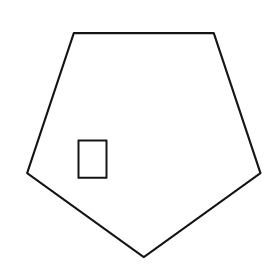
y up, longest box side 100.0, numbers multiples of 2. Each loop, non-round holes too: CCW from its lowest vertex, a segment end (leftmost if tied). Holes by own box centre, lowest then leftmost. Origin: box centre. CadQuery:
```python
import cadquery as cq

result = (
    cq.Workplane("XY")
    .moveTo(0.0, -48.0)
    .lineTo(50.0, -12.0)
    .lineTo(30.0, 48.0)
    .lineTo(-30.0, 48.0)
    .lineTo(-50.0, -12.0)
    .close()
    .moveTo(-28.0, -14.0)
    .lineTo(-16.0, -14.0)
    .lineTo(-16.0, 2.0)
    .lineTo(-28.0, 2.0)
    .close()
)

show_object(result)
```